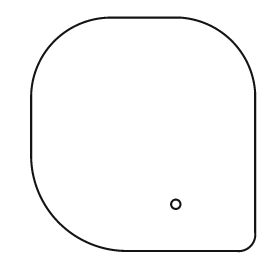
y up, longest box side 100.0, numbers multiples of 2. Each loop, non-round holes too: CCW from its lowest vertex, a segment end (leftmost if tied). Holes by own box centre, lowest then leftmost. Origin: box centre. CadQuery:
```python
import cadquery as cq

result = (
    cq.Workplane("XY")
    .moveTo(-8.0, -50.0)
    .lineTo(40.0, -50.0)
    .threePointArc((46.0, -48.0), (48.0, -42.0))
    .lineTo(48.0, 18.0)
    .threePointArc((38.0, 40.0), (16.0, 50.0))
    .lineTo(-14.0, 50.0)
    .threePointArc((-38.0, 40.0), (-48.0, 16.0))
    .lineTo(-48.0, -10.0)
    .threePointArc((-36.0, -38.0), (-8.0, -50.0))
    .close()
    .moveTo(14.0, -30.0)
    .circle(2.0)
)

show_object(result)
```